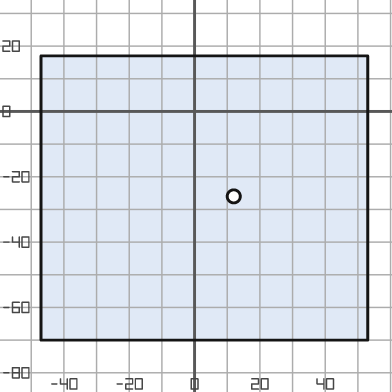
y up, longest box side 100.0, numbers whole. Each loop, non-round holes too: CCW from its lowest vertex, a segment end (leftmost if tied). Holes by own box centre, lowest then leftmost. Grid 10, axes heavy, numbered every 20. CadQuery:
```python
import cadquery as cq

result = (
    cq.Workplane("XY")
    .moveTo(-47.0, -70.0)
    .lineTo(53.0, -70.0)
    .lineTo(53.0, 17.0)
    .lineTo(-47.0, 17.0)
    .close()
    .moveTo(12.0, -26.0)
    .circle(2.0)
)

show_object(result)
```